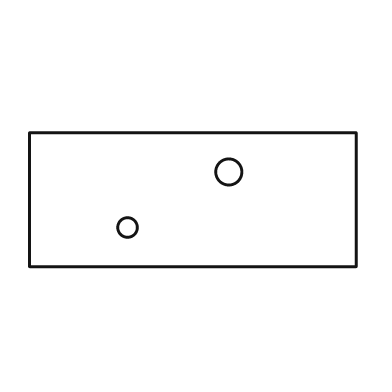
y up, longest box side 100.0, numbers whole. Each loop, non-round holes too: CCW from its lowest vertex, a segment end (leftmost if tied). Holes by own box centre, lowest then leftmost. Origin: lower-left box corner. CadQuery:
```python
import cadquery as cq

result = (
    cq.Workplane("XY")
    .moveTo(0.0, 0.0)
    .lineTo(100.0, 0.0)
    .lineTo(100.0, 41.0)
    .lineTo(0.0, 41.0)
    .close()
    .moveTo(30.0, 12.0)
    .circle(3.0)
    .moveTo(61.0, 29.0)
    .circle(4.0)
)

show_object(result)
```